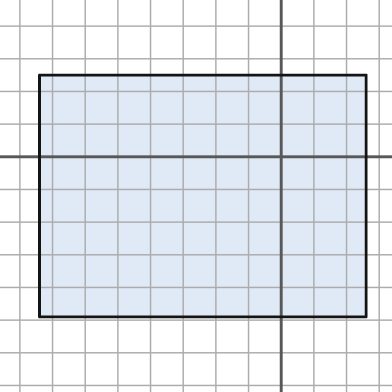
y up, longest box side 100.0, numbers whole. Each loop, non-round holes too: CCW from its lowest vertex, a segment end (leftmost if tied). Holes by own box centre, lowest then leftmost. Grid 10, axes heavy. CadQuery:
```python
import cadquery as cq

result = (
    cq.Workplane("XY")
    .moveTo(-74.0, -49.0)
    .lineTo(26.0, -49.0)
    .lineTo(26.0, 25.0)
    .lineTo(-74.0, 25.0)
    .close()
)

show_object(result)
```